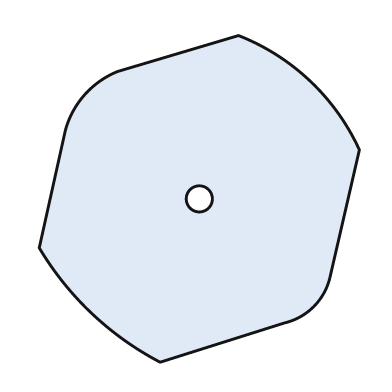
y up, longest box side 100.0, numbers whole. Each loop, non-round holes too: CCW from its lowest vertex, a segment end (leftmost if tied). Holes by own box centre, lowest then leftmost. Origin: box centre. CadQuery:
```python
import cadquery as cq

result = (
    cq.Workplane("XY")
    .moveTo(-12.0, -50.0)
    .lineTo(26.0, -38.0)
    .threePointArc((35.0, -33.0), (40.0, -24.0))
    .lineTo(49.0, 15.0)
    .threePointArc((34.0, 36.0), (12.0, 50.0))
    .lineTo(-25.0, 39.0)
    .threePointArc((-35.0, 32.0), (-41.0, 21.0))
    .lineTo(-49.0, -15.0)
    .threePointArc((-33.0, -35.0), (-12.0, -50.0))
    .close()
    .moveTo(0.0, 0.0)
    .circle(4.0)
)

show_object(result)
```